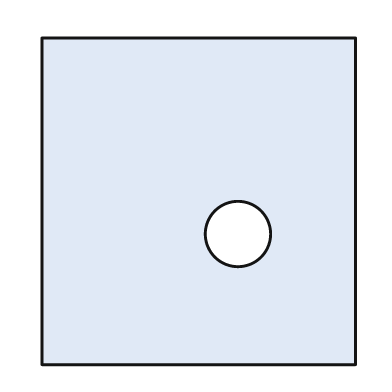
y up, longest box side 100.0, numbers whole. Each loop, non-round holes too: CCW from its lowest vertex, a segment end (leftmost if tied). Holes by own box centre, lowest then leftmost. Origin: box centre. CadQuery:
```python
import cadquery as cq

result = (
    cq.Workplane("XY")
    .moveTo(-48.0, -50.0)
    .lineTo(48.0, -50.0)
    .lineTo(48.0, 50.0)
    .lineTo(-48.0, 50.0)
    .close()
    .moveTo(12.0, -10.0)
    .circle(10.0)
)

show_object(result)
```